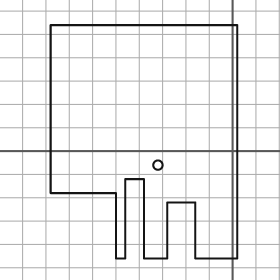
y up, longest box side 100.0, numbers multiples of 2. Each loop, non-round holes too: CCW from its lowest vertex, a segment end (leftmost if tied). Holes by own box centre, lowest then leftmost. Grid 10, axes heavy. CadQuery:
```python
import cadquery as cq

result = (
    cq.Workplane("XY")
    .moveTo(-50.0, -46.0)
    .lineTo(-46.0, -46.0)
    .lineTo(-46.0, -12.0)
    .lineTo(-38.0, -12.0)
    .lineTo(-38.0, -46.0)
    .lineTo(-28.0, -46.0)
    .lineTo(-28.0, -22.0)
    .lineTo(-16.0, -22.0)
    .lineTo(-16.0, -46.0)
    .lineTo(2.0, -46.0)
    .lineTo(2.0, 54.0)
    .lineTo(-78.0, 54.0)
    .lineTo(-78.0, -18.0)
    .lineTo(-50.0, -18.0)
    .close()
    .moveTo(-32.0, -6.0)
    .circle(2.0)
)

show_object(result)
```